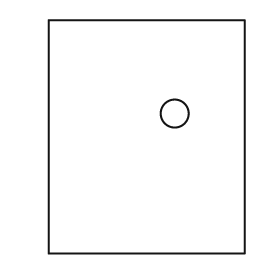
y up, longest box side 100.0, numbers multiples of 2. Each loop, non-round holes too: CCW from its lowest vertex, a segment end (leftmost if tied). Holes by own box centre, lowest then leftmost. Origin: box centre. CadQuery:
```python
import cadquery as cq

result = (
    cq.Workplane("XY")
    .moveTo(-42.0, -50.0)
    .lineTo(42.0, -50.0)
    .lineTo(42.0, 50.0)
    .lineTo(-42.0, 50.0)
    .close()
    .moveTo(12.0, 10.0)
    .circle(6.0)
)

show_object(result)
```